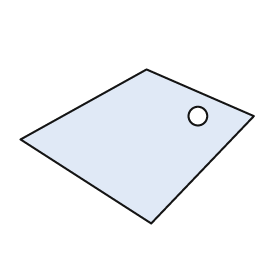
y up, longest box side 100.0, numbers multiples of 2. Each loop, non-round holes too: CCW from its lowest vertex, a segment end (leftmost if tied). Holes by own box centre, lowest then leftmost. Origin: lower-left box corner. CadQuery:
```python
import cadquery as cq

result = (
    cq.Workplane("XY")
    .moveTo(56.0, 0.0)
    .lineTo(100.0, 46.0)
    .lineTo(54.0, 66.0)
    .lineTo(0.0, 36.0)
    .close()
    .moveTo(76.0, 46.0)
    .circle(4.0)
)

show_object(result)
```